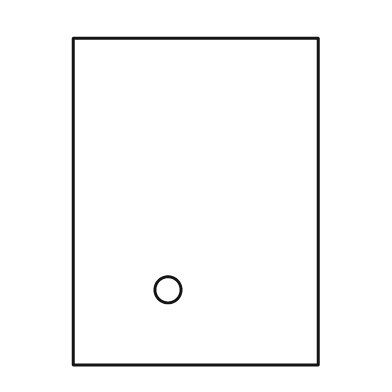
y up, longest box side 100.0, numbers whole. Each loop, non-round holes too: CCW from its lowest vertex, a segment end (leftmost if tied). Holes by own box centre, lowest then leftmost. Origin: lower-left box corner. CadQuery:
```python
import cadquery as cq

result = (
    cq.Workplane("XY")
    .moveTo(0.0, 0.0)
    .lineTo(75.0, 0.0)
    .lineTo(75.0, 100.0)
    .lineTo(0.0, 100.0)
    .close()
    .moveTo(29.0, 23.0)
    .circle(4.0)
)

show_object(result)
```